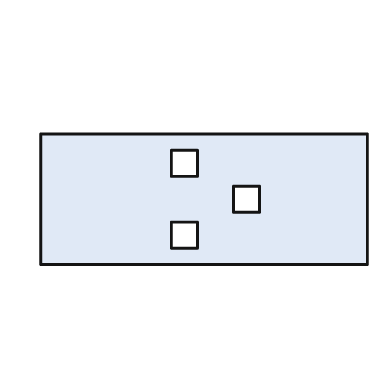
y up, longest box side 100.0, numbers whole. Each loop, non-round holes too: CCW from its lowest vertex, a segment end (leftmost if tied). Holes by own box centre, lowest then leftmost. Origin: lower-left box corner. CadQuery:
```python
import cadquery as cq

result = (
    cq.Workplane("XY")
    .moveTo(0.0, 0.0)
    .lineTo(100.0, 0.0)
    .lineTo(100.0, 40.0)
    .lineTo(0.0, 40.0)
    .close()
    .moveTo(40.0, 5.0)
    .lineTo(48.0, 5.0)
    .lineTo(48.0, 13.0)
    .lineTo(40.0, 13.0)
    .close()
    .moveTo(59.0, 16.0)
    .lineTo(67.0, 16.0)
    .lineTo(67.0, 24.0)
    .lineTo(59.0, 24.0)
    .close()
    .moveTo(40.0, 27.0)
    .lineTo(48.0, 27.0)
    .lineTo(48.0, 35.0)
    .lineTo(40.0, 35.0)
    .close()
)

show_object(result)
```